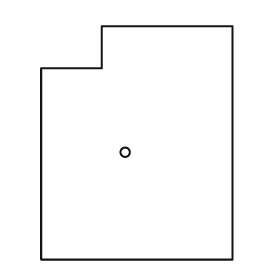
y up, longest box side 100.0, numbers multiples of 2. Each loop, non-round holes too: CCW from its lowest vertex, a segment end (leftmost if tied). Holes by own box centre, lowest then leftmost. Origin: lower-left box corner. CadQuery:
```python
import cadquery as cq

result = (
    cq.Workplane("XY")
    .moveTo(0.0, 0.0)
    .lineTo(82.0, 0.0)
    .lineTo(82.0, 100.0)
    .lineTo(26.0, 100.0)
    .lineTo(26.0, 82.0)
    .lineTo(0.0, 82.0)
    .close()
    .moveTo(36.0, 46.0)
    .circle(2.0)
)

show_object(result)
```